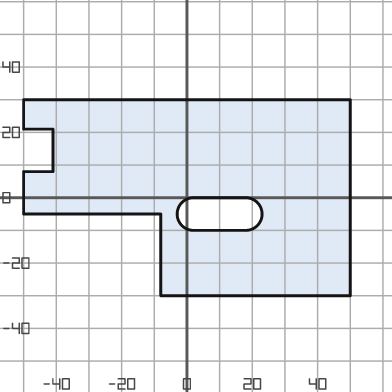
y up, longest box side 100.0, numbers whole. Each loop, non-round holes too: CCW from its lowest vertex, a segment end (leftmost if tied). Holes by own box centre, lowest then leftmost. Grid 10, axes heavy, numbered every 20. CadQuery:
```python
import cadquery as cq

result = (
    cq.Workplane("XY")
    .moveTo(-8.0, -30.0)
    .lineTo(50.0, -30.0)
    .lineTo(50.0, 30.0)
    .lineTo(-50.0, 30.0)
    .lineTo(-50.0, 21.0)
    .lineTo(-41.0, 21.0)
    .lineTo(-41.0, 8.0)
    .lineTo(-50.0, 8.0)
    .lineTo(-50.0, -5.0)
    .lineTo(-8.0, -5.0)
    .close()
    .moveTo(2.0, -10.0)
    .lineTo(18.0, -10.0)
    .threePointArc((23.0, -5.0), (18.0, 0.0))
    .lineTo(2.0, 0.0)
    .threePointArc((-3.0, -5.0), (2.0, -10.0))
    .close()
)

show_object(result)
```